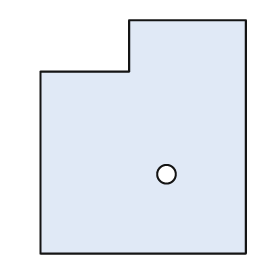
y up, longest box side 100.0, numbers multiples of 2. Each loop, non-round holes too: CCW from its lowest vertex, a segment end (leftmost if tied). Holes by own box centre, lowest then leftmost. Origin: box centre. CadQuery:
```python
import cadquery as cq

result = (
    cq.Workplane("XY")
    .moveTo(-44.0, -50.0)
    .lineTo(44.0, -50.0)
    .lineTo(44.0, 50.0)
    .lineTo(-6.0, 50.0)
    .lineTo(-6.0, 28.0)
    .lineTo(-44.0, 28.0)
    .close()
    .moveTo(10.0, -16.0)
    .circle(4.0)
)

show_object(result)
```